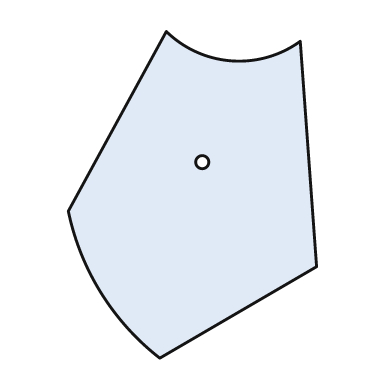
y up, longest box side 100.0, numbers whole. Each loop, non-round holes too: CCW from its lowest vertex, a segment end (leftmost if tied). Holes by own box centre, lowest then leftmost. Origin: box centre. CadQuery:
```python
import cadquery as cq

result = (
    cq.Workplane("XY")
    .moveTo(-10.0, -50.0)
    .lineTo(38.0, -22.0)
    .lineTo(33.0, 47.0)
    .threePointArc((12.0, 41.0), (-8.0, 50.0))
    .lineTo(-38.0, -5.0)
    .threePointArc((-28.0, -30.0), (-10.0, -50.0))
    .close()
    .moveTo(3.0, 10.0)
    .circle(2.0)
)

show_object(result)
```